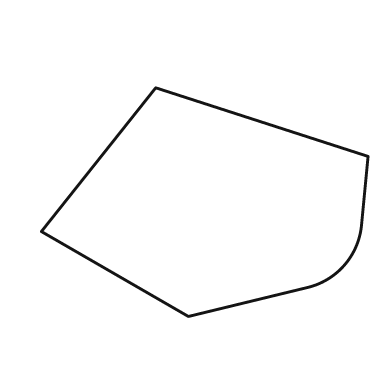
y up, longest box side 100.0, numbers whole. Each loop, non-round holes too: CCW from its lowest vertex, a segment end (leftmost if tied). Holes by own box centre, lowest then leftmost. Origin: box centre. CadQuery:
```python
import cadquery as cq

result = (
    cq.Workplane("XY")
    .moveTo(-5.0, -35.0)
    .lineTo(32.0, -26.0)
    .threePointArc((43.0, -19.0), (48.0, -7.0))
    .lineTo(50.0, 14.0)
    .lineTo(-15.0, 35.0)
    .lineTo(-50.0, -9.0)
    .close()
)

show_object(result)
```